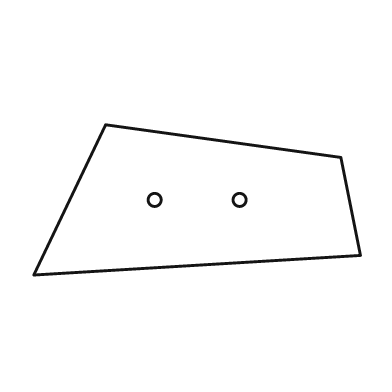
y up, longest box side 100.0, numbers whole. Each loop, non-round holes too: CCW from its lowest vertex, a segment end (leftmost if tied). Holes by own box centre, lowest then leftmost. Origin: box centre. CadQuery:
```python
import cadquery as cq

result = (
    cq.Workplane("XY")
    .moveTo(-50.0, -23.0)
    .lineTo(50.0, -17.0)
    .lineTo(44.0, 13.0)
    .lineTo(-28.0, 23.0)
    .close()
    .moveTo(-13.0, 0.0)
    .circle(2.0)
    .moveTo(13.0, 0.0)
    .circle(2.0)
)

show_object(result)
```